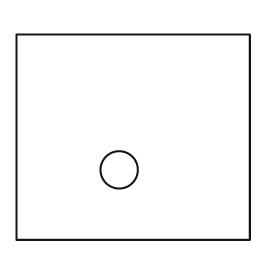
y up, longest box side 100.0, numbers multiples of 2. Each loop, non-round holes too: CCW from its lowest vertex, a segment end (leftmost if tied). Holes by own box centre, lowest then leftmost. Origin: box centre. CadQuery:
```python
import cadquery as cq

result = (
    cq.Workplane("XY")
    .moveTo(-50.0, -44.0)
    .lineTo(50.0, -44.0)
    .lineTo(50.0, 44.0)
    .lineTo(-50.0, 44.0)
    .close()
    .moveTo(-6.0, -14.0)
    .circle(8.0)
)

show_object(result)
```